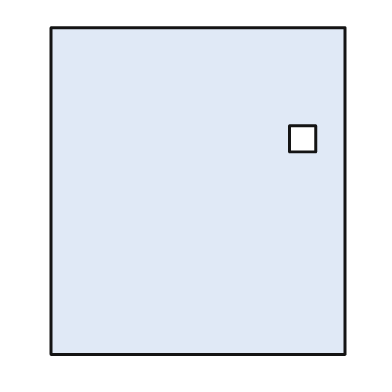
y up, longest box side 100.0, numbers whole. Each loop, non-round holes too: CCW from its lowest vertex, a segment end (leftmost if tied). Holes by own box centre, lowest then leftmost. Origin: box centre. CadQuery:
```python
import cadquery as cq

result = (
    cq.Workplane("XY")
    .moveTo(-45.0, -50.0)
    .lineTo(45.0, -50.0)
    .lineTo(45.0, 50.0)
    .lineTo(-45.0, 50.0)
    .close()
    .moveTo(28.0, 12.0)
    .lineTo(36.0, 12.0)
    .lineTo(36.0, 20.0)
    .lineTo(28.0, 20.0)
    .close()
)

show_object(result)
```